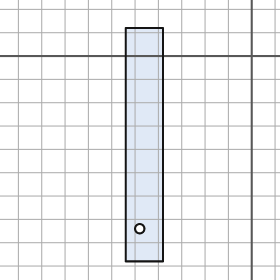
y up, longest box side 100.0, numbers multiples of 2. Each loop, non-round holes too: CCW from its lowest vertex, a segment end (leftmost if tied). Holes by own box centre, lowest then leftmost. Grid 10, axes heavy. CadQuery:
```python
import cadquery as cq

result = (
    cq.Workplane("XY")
    .moveTo(-54.0, -88.0)
    .lineTo(-38.0, -88.0)
    .lineTo(-38.0, 12.0)
    .lineTo(-54.0, 12.0)
    .close()
    .moveTo(-48.0, -74.0)
    .circle(2.0)
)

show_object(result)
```